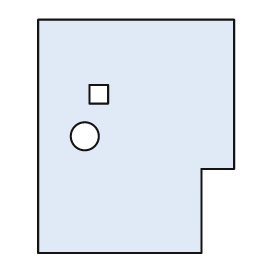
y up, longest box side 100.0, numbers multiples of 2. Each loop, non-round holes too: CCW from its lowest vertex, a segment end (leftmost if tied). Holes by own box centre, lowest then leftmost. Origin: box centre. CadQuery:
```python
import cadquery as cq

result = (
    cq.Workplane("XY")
    .moveTo(-42.0, -50.0)
    .lineTo(28.0, -50.0)
    .lineTo(28.0, -14.0)
    .lineTo(42.0, -14.0)
    .lineTo(42.0, 50.0)
    .lineTo(-42.0, 50.0)
    .close()
    .moveTo(-22.0, 0.0)
    .circle(6.0)
    .moveTo(-20.0, 14.0)
    .lineTo(-12.0, 14.0)
    .lineTo(-12.0, 22.0)
    .lineTo(-20.0, 22.0)
    .close()
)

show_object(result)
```